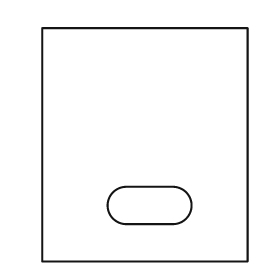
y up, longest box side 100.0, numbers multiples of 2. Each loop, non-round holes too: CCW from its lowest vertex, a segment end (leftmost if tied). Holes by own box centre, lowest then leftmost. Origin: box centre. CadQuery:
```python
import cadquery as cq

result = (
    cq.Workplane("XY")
    .moveTo(-44.0, -50.0)
    .lineTo(44.0, -50.0)
    .lineTo(44.0, 50.0)
    .lineTo(-44.0, 50.0)
    .close()
    .moveTo(-8.0, -34.0)
    .lineTo(12.0, -34.0)
    .threePointArc((20.0, -26.0), (12.0, -18.0))
    .lineTo(-8.0, -18.0)
    .threePointArc((-16.0, -26.0), (-8.0, -34.0))
    .close()
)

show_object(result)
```